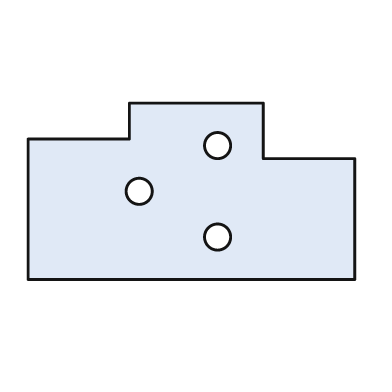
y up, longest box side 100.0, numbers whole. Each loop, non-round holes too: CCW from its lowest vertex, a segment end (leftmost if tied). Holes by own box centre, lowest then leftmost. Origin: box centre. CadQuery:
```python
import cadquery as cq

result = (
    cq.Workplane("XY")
    .moveTo(-50.0, -27.0)
    .lineTo(50.0, -27.0)
    .lineTo(50.0, 10.0)
    .lineTo(22.0, 10.0)
    .lineTo(22.0, 27.0)
    .lineTo(-19.0, 27.0)
    .lineTo(-19.0, 16.0)
    .lineTo(-50.0, 16.0)
    .close()
    .moveTo(8.0, -14.0)
    .circle(4.0)
    .moveTo(-16.0, 0.0)
    .circle(4.0)
    .moveTo(8.0, 14.0)
    .circle(4.0)
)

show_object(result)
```